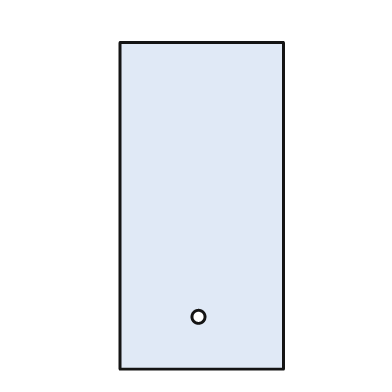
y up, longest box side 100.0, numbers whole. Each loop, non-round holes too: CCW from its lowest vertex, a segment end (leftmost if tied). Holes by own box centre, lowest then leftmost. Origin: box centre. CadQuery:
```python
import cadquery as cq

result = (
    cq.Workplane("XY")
    .moveTo(-25.0, -50.0)
    .lineTo(25.0, -50.0)
    .lineTo(25.0, 50.0)
    .lineTo(-25.0, 50.0)
    .close()
    .moveTo(-1.0, -34.0)
    .circle(2.0)
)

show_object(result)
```